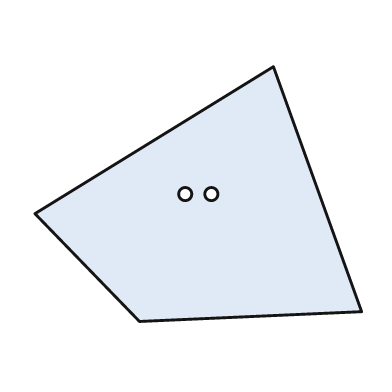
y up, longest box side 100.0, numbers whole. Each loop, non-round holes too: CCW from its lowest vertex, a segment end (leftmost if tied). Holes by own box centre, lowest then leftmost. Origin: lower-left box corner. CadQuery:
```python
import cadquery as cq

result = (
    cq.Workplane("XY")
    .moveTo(32.0, 0.0)
    .lineTo(100.0, 3.0)
    .lineTo(73.0, 78.0)
    .lineTo(0.0, 33.0)
    .close()
    .moveTo(46.0, 39.0)
    .circle(2.0)
    .moveTo(54.0, 39.0)
    .circle(2.0)
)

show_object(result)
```